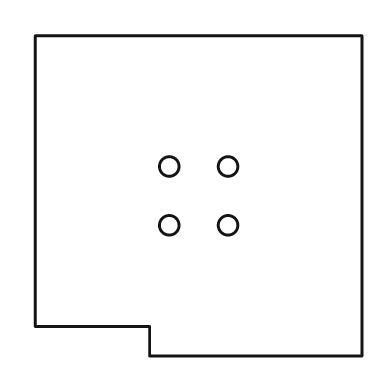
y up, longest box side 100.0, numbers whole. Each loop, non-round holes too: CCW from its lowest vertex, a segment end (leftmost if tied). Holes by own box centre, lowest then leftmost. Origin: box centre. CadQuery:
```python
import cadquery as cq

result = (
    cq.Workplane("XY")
    .moveTo(-15.0, -49.0)
    .lineTo(50.0, -49.0)
    .lineTo(50.0, 49.0)
    .lineTo(-50.0, 49.0)
    .lineTo(-50.0, -40.0)
    .lineTo(-15.0, -40.0)
    .close()
    .moveTo(-9.0, -9.0)
    .circle(3.0)
    .moveTo(9.0, -9.0)
    .circle(3.0)
    .moveTo(-9.0, 9.0)
    .circle(3.0)
    .moveTo(9.0, 9.0)
    .circle(3.0)
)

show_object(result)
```